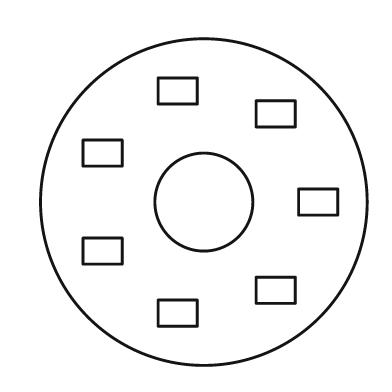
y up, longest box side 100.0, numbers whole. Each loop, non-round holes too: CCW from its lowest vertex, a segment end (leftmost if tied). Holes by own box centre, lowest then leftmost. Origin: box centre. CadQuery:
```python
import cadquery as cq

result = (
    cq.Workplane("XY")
    .moveTo(0.0, 0.0)
    .circle(50.0)
    .moveTo(-14.0, -38.0)
    .lineTo(-2.0, -38.0)
    .lineTo(-2.0, -30.0)
    .lineTo(-14.0, -30.0)
    .close()
    .moveTo(16.0, -31.0)
    .lineTo(28.0, -31.0)
    .lineTo(28.0, -23.0)
    .lineTo(16.0, -23.0)
    .close()
    .moveTo(-37.0, -19.0)
    .lineTo(-25.0, -19.0)
    .lineTo(-25.0, -11.0)
    .lineTo(-37.0, -11.0)
    .close()
    .moveTo(0.0, 0.0)
    .circle(15.0)
    .moveTo(29.0, -4.0)
    .lineTo(41.0, -4.0)
    .lineTo(41.0, 4.0)
    .lineTo(29.0, 4.0)
    .close()
    .moveTo(-37.0, 11.0)
    .lineTo(-25.0, 11.0)
    .lineTo(-25.0, 19.0)
    .lineTo(-37.0, 19.0)
    .close()
    .moveTo(16.0, 23.0)
    .lineTo(28.0, 23.0)
    .lineTo(28.0, 31.0)
    .lineTo(16.0, 31.0)
    .close()
    .moveTo(-14.0, 30.0)
    .lineTo(-2.0, 30.0)
    .lineTo(-2.0, 38.0)
    .lineTo(-14.0, 38.0)
    .close()
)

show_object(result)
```